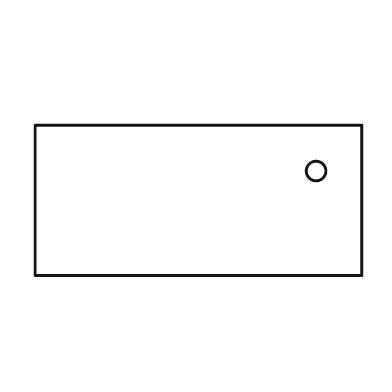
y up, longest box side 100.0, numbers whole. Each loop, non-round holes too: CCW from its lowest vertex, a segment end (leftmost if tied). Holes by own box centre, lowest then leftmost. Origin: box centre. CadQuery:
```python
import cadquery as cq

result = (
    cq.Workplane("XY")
    .moveTo(-50.0, -23.0)
    .lineTo(50.0, -23.0)
    .lineTo(50.0, 23.0)
    .lineTo(-50.0, 23.0)
    .close()
    .moveTo(36.0, 9.0)
    .circle(3.0)
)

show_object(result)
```